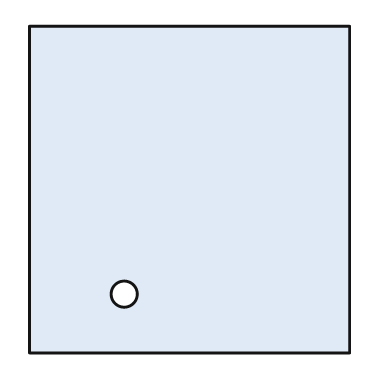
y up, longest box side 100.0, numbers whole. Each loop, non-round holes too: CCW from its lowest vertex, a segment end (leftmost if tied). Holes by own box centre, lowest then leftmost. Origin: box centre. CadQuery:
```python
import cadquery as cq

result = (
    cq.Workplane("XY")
    .moveTo(-49.0, -50.0)
    .lineTo(49.0, -50.0)
    .lineTo(49.0, 50.0)
    .lineTo(-49.0, 50.0)
    .close()
    .moveTo(-20.0, -32.0)
    .circle(4.0)
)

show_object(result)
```